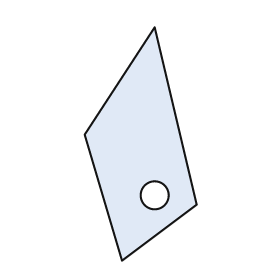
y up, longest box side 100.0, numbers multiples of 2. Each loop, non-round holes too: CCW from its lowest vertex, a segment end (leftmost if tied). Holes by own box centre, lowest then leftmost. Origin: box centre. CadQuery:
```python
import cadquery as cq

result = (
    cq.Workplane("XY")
    .moveTo(-8.0, -50.0)
    .lineTo(24.0, -26.0)
    .lineTo(6.0, 50.0)
    .lineTo(-24.0, 4.0)
    .close()
    .moveTo(6.0, -22.0)
    .circle(6.0)
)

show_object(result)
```